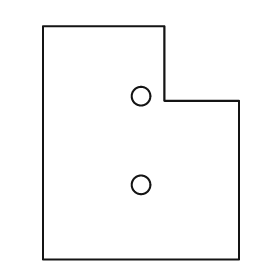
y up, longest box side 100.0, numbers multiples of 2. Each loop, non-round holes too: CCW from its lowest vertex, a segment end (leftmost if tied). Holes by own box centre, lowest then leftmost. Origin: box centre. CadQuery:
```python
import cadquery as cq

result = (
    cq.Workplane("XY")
    .moveTo(-42.0, -50.0)
    .lineTo(42.0, -50.0)
    .lineTo(42.0, 18.0)
    .lineTo(10.0, 18.0)
    .lineTo(10.0, 50.0)
    .lineTo(-42.0, 50.0)
    .close()
    .moveTo(0.0, -18.0)
    .circle(4.0)
    .moveTo(0.0, 20.0)
    .circle(4.0)
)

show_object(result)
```